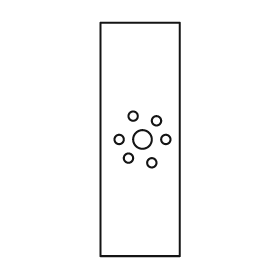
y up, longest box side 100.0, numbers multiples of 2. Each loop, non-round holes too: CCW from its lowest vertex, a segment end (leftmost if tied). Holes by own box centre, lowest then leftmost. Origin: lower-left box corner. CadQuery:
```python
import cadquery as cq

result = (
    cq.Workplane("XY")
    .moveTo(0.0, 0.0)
    .lineTo(34.0, 0.0)
    .lineTo(34.0, 100.0)
    .lineTo(0.0, 100.0)
    .close()
    .moveTo(22.0, 40.0)
    .circle(2.0)
    .moveTo(12.0, 42.0)
    .circle(2.0)
    .moveTo(8.0, 50.0)
    .circle(2.0)
    .moveTo(18.0, 50.0)
    .circle(4.0)
    .moveTo(28.0, 50.0)
    .circle(2.0)
    .moveTo(24.0, 58.0)
    .circle(2.0)
    .moveTo(14.0, 60.0)
    .circle(2.0)
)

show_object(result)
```